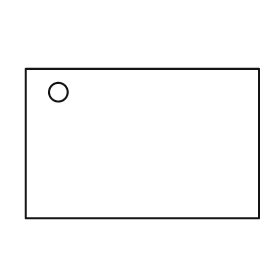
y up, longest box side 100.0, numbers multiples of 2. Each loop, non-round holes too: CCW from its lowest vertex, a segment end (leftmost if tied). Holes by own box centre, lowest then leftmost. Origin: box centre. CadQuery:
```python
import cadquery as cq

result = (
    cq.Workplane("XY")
    .moveTo(-50.0, -32.0)
    .lineTo(50.0, -32.0)
    .lineTo(50.0, 32.0)
    .lineTo(-50.0, 32.0)
    .close()
    .moveTo(-36.0, 22.0)
    .circle(4.0)
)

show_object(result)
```